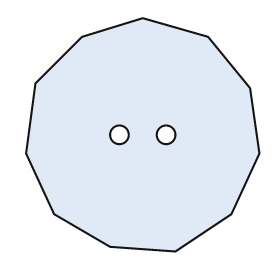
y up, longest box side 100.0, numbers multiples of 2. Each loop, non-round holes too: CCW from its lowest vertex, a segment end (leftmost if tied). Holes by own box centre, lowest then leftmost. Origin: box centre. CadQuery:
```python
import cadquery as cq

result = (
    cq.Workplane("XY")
    .moveTo(14.0, -50.0)
    .lineTo(38.0, -34.0)
    .lineTo(50.0, -8.0)
    .lineTo(46.0, 20.0)
    .lineTo(28.0, 42.0)
    .lineTo(0.0, 50.0)
    .lineTo(-26.0, 42.0)
    .lineTo(-46.0, 22.0)
    .lineTo(-50.0, -8.0)
    .lineTo(-38.0, -34.0)
    .lineTo(-14.0, -48.0)
    .close()
    .moveTo(-10.0, 0.0)
    .circle(4.0)
    .moveTo(10.0, 0.0)
    .circle(4.0)
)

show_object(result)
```